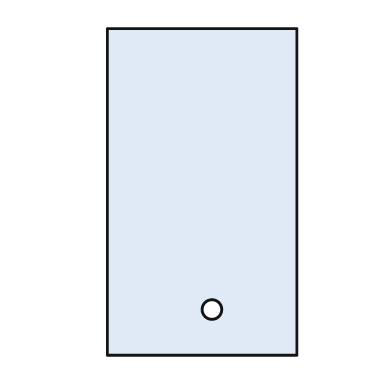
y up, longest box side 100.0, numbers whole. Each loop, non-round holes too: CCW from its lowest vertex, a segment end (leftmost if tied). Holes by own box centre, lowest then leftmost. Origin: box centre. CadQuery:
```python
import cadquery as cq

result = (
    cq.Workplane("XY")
    .moveTo(-29.0, -50.0)
    .lineTo(29.0, -50.0)
    .lineTo(29.0, 50.0)
    .lineTo(-29.0, 50.0)
    .close()
    .moveTo(3.0, -36.0)
    .circle(3.0)
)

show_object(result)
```